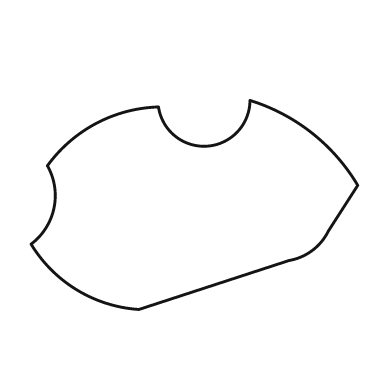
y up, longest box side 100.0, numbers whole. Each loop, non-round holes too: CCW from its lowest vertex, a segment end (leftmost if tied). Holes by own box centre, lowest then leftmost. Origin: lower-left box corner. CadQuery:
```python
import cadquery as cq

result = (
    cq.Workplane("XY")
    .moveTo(33.0, 0.0)
    .lineTo(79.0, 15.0)
    .threePointArc((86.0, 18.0), (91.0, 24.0))
    .lineTo(100.0, 38.0)
    .threePointArc((86.0, 54.0), (67.0, 64.0))
    .threePointArc((54.0, 50.0), (39.0, 62.0))
    .threePointArc((20.0, 57.0), (5.0, 44.0))
    .threePointArc((7.0, 31.0), (0.0, 20.0))
    .threePointArc((14.0, 6.0), (33.0, 0.0))
    .close()
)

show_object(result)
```